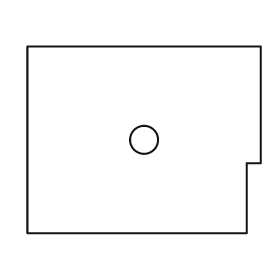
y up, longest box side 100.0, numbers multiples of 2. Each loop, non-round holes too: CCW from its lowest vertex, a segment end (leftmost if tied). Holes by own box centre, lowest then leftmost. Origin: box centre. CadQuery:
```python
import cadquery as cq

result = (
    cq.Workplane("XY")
    .moveTo(-50.0, -40.0)
    .lineTo(44.0, -40.0)
    .lineTo(44.0, -10.0)
    .lineTo(50.0, -10.0)
    .lineTo(50.0, 40.0)
    .lineTo(-50.0, 40.0)
    .close()
    .moveTo(0.0, 0.0)
    .circle(6.0)
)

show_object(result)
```